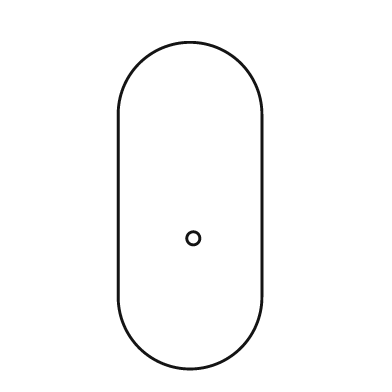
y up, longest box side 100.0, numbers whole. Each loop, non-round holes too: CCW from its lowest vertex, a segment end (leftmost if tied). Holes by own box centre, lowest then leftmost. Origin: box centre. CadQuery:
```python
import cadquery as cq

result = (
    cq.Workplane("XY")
    .moveTo(-22.0, -28.0)
    .threePointArc((0.0, -50.0), (22.0, -28.0))
    .lineTo(22.0, 28.0)
    .threePointArc((0.0, 50.0), (-22.0, 28.0))
    .close()
    .moveTo(1.0, -10.0)
    .circle(2.0)
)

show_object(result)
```